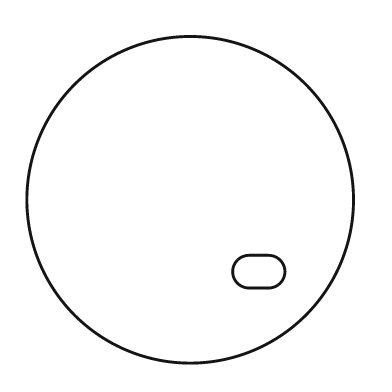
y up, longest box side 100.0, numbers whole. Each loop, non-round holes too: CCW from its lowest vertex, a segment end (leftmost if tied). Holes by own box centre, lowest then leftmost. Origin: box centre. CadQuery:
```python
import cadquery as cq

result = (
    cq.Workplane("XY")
    .moveTo(0.0, 0.0)
    .circle(50.0)
    .moveTo(18.0, -27.0)
    .lineTo(24.0, -27.0)
    .threePointArc((29.0, -22.0), (24.0, -17.0))
    .lineTo(18.0, -17.0)
    .threePointArc((13.0, -22.0), (18.0, -27.0))
    .close()
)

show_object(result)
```